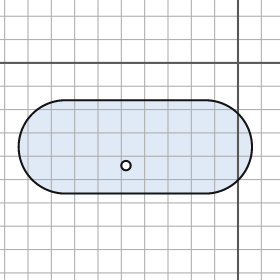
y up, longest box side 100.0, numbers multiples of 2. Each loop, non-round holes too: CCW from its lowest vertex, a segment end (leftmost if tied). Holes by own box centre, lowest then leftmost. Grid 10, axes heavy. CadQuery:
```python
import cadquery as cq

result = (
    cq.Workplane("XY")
    .moveTo(-74.0, -56.0)
    .lineTo(-14.0, -56.0)
    .threePointArc((6.0, -36.0), (-14.0, -16.0))
    .lineTo(-74.0, -16.0)
    .threePointArc((-94.0, -36.0), (-74.0, -56.0))
    .close()
    .moveTo(-48.0, -44.0)
    .circle(2.0)
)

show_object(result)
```